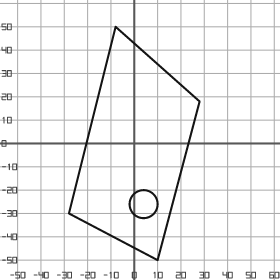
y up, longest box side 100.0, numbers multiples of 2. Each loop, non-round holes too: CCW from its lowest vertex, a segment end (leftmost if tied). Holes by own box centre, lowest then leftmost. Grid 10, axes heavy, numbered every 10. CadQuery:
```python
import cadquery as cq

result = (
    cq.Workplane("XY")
    .moveTo(10.0, -50.0)
    .lineTo(28.0, 18.0)
    .lineTo(-8.0, 50.0)
    .lineTo(-28.0, -30.0)
    .close()
    .moveTo(4.0, -26.0)
    .circle(6.0)
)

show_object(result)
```